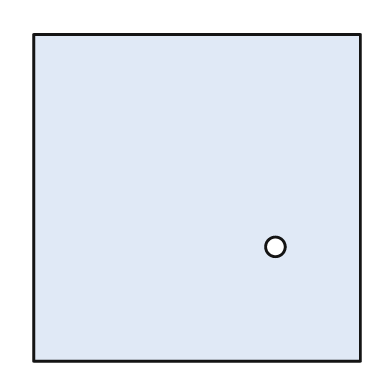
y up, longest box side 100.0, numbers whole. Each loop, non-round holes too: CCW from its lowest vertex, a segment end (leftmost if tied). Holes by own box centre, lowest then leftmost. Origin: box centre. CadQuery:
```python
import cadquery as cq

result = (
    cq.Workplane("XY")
    .moveTo(-50.0, -50.0)
    .lineTo(50.0, -50.0)
    .lineTo(50.0, 50.0)
    .lineTo(-50.0, 50.0)
    .close()
    .moveTo(24.0, -15.0)
    .circle(3.0)
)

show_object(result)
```